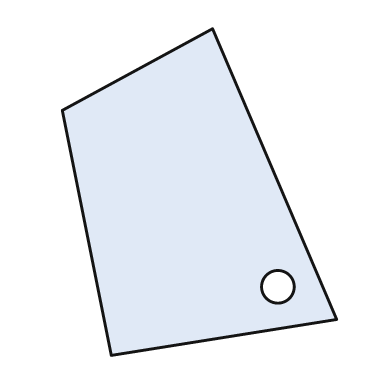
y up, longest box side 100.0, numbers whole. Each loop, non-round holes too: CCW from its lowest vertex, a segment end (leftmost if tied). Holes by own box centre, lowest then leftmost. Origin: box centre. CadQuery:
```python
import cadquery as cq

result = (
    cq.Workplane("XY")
    .moveTo(-27.0, -50.0)
    .lineTo(42.0, -39.0)
    .lineTo(4.0, 50.0)
    .lineTo(-42.0, 25.0)
    .close()
    .moveTo(24.0, -29.0)
    .circle(5.0)
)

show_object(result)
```